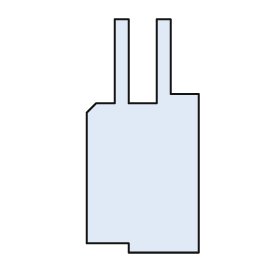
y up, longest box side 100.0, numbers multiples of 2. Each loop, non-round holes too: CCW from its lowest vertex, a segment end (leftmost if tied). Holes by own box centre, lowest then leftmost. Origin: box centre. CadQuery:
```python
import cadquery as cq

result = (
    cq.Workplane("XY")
    .moveTo(-6.0, -50.0)
    .lineTo(24.0, -50.0)
    .lineTo(24.0, 18.0)
    .lineTo(12.0, 18.0)
    .lineTo(12.0, 50.0)
    .lineTo(6.0, 50.0)
    .lineTo(6.0, 14.0)
    .lineTo(-6.0, 14.0)
    .lineTo(-6.0, 50.0)
    .lineTo(-12.0, 50.0)
    .lineTo(-12.0, 14.0)
    .lineTo(-20.0, 14.0)
    .lineTo(-24.0, 10.0)
    .lineTo(-24.0, -46.0)
    .lineTo(-6.0, -46.0)
    .close()
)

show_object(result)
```